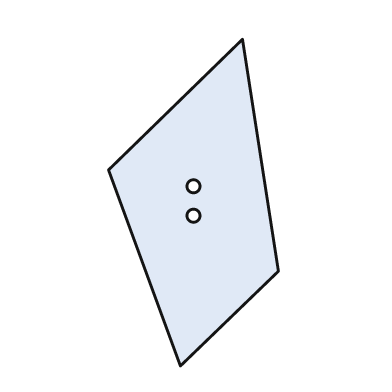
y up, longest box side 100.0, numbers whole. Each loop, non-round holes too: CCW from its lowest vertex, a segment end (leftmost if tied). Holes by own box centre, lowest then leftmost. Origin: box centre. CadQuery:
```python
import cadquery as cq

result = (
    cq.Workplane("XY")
    .moveTo(-4.0, -50.0)
    .lineTo(26.0, -21.0)
    .lineTo(15.0, 50.0)
    .lineTo(-26.0, 10.0)
    .close()
    .moveTo(0.0, -4.0)
    .circle(2.0)
    .moveTo(0.0, 5.0)
    .circle(2.0)
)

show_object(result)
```